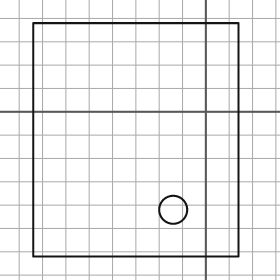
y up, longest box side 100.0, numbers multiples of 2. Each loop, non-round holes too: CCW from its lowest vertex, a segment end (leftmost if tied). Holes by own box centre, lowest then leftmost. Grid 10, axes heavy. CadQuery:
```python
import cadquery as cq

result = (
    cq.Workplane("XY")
    .moveTo(-74.0, -62.0)
    .lineTo(14.0, -62.0)
    .lineTo(14.0, 38.0)
    .lineTo(-74.0, 38.0)
    .close()
    .moveTo(-14.0, -42.0)
    .circle(6.0)
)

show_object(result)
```